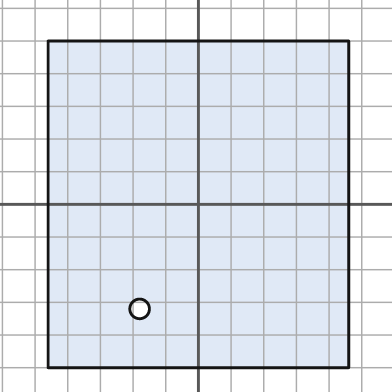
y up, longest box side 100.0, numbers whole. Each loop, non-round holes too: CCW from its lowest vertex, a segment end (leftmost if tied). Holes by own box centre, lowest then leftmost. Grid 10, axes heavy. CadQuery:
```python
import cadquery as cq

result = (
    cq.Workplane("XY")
    .moveTo(-46.0, -50.0)
    .lineTo(46.0, -50.0)
    .lineTo(46.0, 50.0)
    .lineTo(-46.0, 50.0)
    .close()
    .moveTo(-18.0, -32.0)
    .circle(3.0)
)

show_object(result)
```